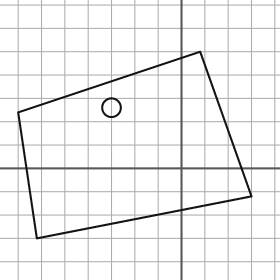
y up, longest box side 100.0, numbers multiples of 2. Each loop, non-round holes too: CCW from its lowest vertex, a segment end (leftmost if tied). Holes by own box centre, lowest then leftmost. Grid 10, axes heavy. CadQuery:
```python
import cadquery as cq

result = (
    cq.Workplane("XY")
    .moveTo(-62.0, -30.0)
    .lineTo(30.0, -12.0)
    .lineTo(8.0, 50.0)
    .lineTo(-70.0, 24.0)
    .close()
    .moveTo(-30.0, 26.0)
    .circle(4.0)
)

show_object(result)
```